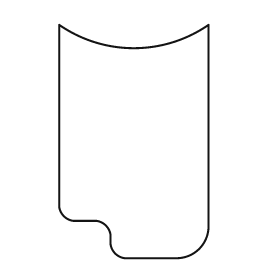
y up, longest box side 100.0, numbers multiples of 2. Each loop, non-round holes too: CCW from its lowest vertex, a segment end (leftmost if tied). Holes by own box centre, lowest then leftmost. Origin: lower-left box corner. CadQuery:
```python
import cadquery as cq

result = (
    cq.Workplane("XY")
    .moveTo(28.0, 0.0)
    .lineTo(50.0, 0.0)
    .threePointArc((60.0, 4.0), (64.0, 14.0))
    .lineTo(64.0, 100.0)
    .threePointArc((32.0, 90.0), (0.0, 100.0))
    .lineTo(0.0, 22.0)
    .threePointArc((2.0, 18.0), (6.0, 16.0))
    .lineTo(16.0, 16.0)
    .threePointArc((20.0, 14.0), (22.0, 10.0))
    .lineTo(22.0, 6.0)
    .threePointArc((24.0, 2.0), (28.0, 0.0))
    .close()
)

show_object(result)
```